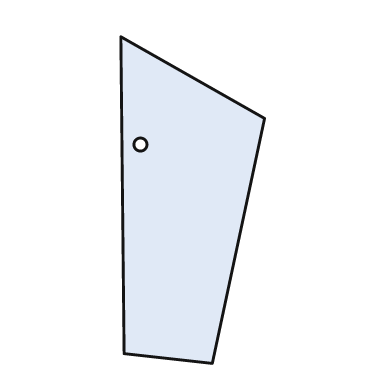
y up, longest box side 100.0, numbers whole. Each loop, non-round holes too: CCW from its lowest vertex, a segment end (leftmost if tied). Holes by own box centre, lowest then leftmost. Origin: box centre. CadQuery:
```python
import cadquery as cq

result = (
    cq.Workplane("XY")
    .moveTo(6.0, -50.0)
    .lineTo(22.0, 25.0)
    .lineTo(-22.0, 50.0)
    .lineTo(-21.0, -47.0)
    .close()
    .moveTo(-16.0, 17.0)
    .circle(2.0)
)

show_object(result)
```